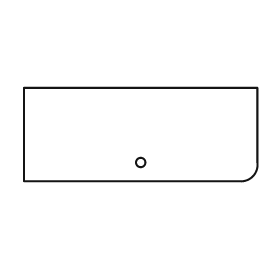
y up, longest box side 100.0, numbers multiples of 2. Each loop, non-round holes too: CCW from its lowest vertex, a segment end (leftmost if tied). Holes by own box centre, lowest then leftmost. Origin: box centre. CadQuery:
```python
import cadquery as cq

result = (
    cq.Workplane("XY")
    .moveTo(-50.0, -20.0)
    .lineTo(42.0, -20.0)
    .threePointArc((48.0, -18.0), (50.0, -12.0))
    .lineTo(50.0, 20.0)
    .lineTo(-50.0, 20.0)
    .close()
    .moveTo(0.0, -12.0)
    .circle(2.0)
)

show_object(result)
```